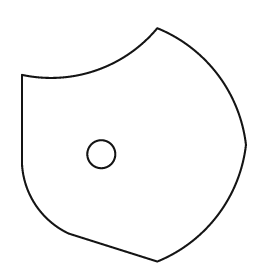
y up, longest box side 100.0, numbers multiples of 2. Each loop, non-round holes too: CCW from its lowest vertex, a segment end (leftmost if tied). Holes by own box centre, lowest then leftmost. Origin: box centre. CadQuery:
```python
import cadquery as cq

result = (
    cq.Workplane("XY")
    .moveTo(10.0, -50.0)
    .threePointArc((36.0, -30.0), (48.0, 0.0))
    .threePointArc((36.0, 30.0), (10.0, 50.0))
    .threePointArc((-16.0, 32.0), (-48.0, 30.0))
    .lineTo(-48.0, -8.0)
    .threePointArc((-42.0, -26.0), (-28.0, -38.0))
    .close()
    .moveTo(-14.0, -4.0)
    .circle(6.0)
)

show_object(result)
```